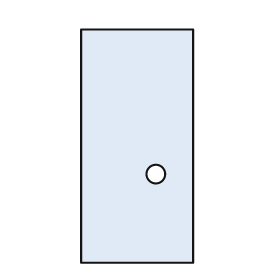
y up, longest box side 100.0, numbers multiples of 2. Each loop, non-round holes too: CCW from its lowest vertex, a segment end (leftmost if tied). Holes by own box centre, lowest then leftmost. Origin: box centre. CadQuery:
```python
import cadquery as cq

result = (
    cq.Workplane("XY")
    .moveTo(-24.0, -50.0)
    .lineTo(24.0, -50.0)
    .lineTo(24.0, 50.0)
    .lineTo(-24.0, 50.0)
    .close()
    .moveTo(8.0, -12.0)
    .circle(4.0)
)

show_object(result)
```